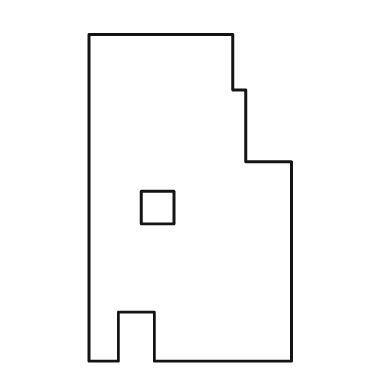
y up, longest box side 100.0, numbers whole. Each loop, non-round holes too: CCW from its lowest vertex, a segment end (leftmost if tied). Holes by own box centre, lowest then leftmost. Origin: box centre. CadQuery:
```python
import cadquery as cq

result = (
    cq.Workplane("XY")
    .moveTo(-31.0, -50.0)
    .lineTo(-22.0, -50.0)
    .lineTo(-22.0, -35.0)
    .lineTo(-11.0, -35.0)
    .lineTo(-11.0, -50.0)
    .lineTo(31.0, -50.0)
    .lineTo(31.0, 11.0)
    .lineTo(17.0, 11.0)
    .lineTo(17.0, 33.0)
    .lineTo(13.0, 33.0)
    .lineTo(13.0, 50.0)
    .lineTo(-31.0, 50.0)
    .close()
    .moveTo(-15.0, -8.0)
    .lineTo(-5.0, -8.0)
    .lineTo(-5.0, 2.0)
    .lineTo(-15.0, 2.0)
    .close()
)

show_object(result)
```